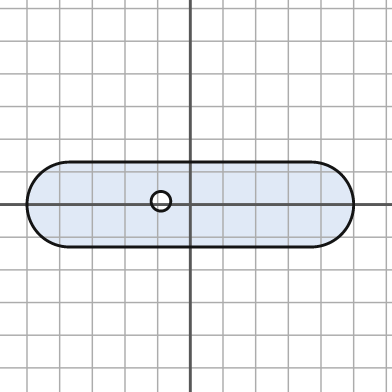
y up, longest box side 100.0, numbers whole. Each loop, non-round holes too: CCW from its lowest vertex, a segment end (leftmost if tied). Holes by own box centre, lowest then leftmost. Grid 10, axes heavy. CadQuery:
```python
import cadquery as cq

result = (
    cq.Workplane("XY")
    .moveTo(-37.0, -13.0)
    .lineTo(37.0, -13.0)
    .threePointArc((50.0, 0.0), (37.0, 13.0))
    .lineTo(-37.0, 13.0)
    .threePointArc((-50.0, 0.0), (-37.0, -13.0))
    .close()
    .moveTo(-9.0, 1.0)
    .circle(3.0)
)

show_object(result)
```